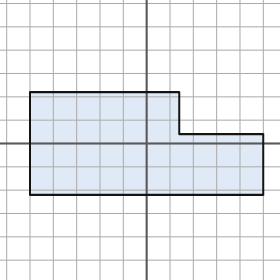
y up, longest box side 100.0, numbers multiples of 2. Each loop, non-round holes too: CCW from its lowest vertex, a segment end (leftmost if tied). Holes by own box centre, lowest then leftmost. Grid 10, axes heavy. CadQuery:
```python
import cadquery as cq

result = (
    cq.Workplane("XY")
    .moveTo(-50.0, -22.0)
    .lineTo(50.0, -22.0)
    .lineTo(50.0, 4.0)
    .lineTo(14.0, 4.0)
    .lineTo(14.0, 22.0)
    .lineTo(-50.0, 22.0)
    .close()
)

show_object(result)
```